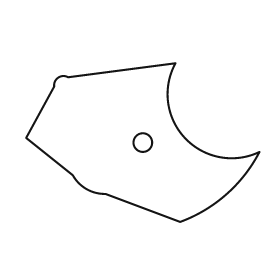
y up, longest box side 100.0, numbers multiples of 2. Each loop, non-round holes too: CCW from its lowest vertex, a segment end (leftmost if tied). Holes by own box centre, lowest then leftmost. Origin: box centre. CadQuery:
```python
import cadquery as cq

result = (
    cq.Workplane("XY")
    .moveTo(16.0, -34.0)
    .threePointArc((36.0, -22.0), (50.0, -4.0))
    .threePointArc((18.0, 2.0), (14.0, 34.0))
    .lineTo(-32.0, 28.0)
    .threePointArc((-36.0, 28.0), (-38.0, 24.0))
    .lineTo(-50.0, 2.0)
    .lineTo(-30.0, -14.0)
    .threePointArc((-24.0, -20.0), (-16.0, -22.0))
    .close()
    .moveTo(0.0, 0.0)
    .circle(4.0)
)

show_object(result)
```